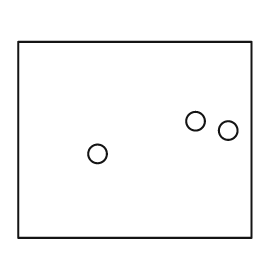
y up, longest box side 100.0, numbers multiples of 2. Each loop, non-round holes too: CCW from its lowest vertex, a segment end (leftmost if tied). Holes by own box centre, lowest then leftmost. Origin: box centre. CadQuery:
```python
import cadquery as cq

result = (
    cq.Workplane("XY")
    .moveTo(-50.0, -42.0)
    .lineTo(50.0, -42.0)
    .lineTo(50.0, 42.0)
    .lineTo(-50.0, 42.0)
    .close()
    .moveTo(-16.0, -6.0)
    .circle(4.0)
    .moveTo(40.0, 4.0)
    .circle(4.0)
    .moveTo(26.0, 8.0)
    .circle(4.0)
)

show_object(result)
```